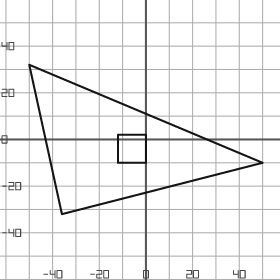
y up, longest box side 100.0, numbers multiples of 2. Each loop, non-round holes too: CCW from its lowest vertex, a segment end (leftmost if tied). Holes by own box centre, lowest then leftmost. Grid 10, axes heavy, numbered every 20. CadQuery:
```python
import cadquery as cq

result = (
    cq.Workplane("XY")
    .moveTo(-36.0, -32.0)
    .lineTo(50.0, -10.0)
    .lineTo(-50.0, 32.0)
    .close()
    .moveTo(-12.0, -10.0)
    .lineTo(0.0, -10.0)
    .lineTo(0.0, 2.0)
    .lineTo(-12.0, 2.0)
    .close()
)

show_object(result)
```